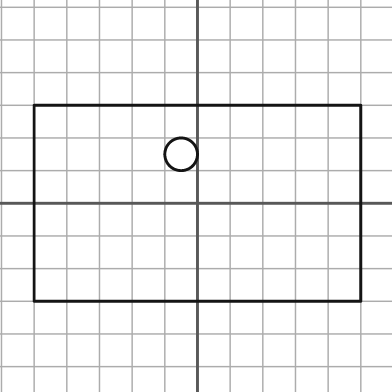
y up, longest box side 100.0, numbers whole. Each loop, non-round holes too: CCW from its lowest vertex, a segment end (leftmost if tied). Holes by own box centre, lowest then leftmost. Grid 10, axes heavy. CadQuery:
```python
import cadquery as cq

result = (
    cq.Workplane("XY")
    .moveTo(-50.0, -30.0)
    .lineTo(50.0, -30.0)
    .lineTo(50.0, 30.0)
    .lineTo(-50.0, 30.0)
    .close()
    .moveTo(-5.0, 15.0)
    .circle(5.0)
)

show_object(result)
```